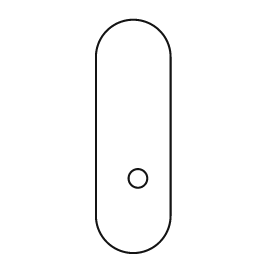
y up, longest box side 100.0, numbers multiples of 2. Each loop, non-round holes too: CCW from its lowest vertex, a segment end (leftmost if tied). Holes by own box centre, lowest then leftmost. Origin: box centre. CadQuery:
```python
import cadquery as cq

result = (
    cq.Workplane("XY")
    .moveTo(-16.0, -34.0)
    .threePointArc((0.0, -50.0), (16.0, -34.0))
    .lineTo(16.0, 34.0)
    .threePointArc((0.0, 50.0), (-16.0, 34.0))
    .close()
    .moveTo(2.0, -18.0)
    .circle(4.0)
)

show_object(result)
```